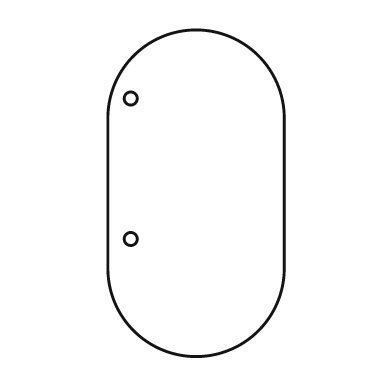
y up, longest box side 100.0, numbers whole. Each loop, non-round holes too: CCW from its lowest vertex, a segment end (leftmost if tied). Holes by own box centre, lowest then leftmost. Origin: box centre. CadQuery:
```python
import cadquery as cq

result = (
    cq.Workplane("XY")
    .moveTo(-27.0, -23.0)
    .threePointArc((0.0, -50.0), (27.0, -23.0))
    .lineTo(27.0, 23.0)
    .threePointArc((0.0, 50.0), (-27.0, 23.0))
    .close()
    .moveTo(-20.0, -14.0)
    .circle(2.0)
    .moveTo(-20.0, 29.0)
    .circle(2.0)
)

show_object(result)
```